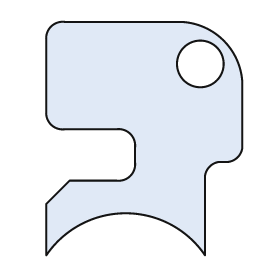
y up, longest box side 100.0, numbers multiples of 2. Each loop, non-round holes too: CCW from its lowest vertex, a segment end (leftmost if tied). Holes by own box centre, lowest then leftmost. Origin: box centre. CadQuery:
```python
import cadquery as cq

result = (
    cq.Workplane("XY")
    .moveTo(-42.0, -50.0)
    .threePointArc((-8.0, -32.0), (26.0, -50.0))
    .lineTo(26.0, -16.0)
    .threePointArc((28.0, -12.0), (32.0, -10.0))
    .lineTo(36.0, -10.0)
    .threePointArc((40.0, -8.0), (42.0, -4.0))
    .lineTo(42.0, 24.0)
    .threePointArc((34.0, 42.0), (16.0, 50.0))
    .lineTo(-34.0, 50.0)
    .threePointArc((-40.0, 48.0), (-42.0, 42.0))
    .lineTo(-42.0, 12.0)
    .threePointArc((-40.0, 6.0), (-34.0, 4.0))
    .lineTo(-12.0, 4.0)
    .threePointArc((-6.0, 2.0), (-4.0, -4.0))
    .lineTo(-4.0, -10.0)
    .threePointArc((-6.0, -16.0), (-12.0, -18.0))
    .lineTo(-32.0, -18.0)
    .lineTo(-42.0, -28.0)
    .close()
    .moveTo(24.0, 32.0)
    .circle(10.0)
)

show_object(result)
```